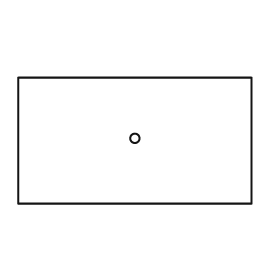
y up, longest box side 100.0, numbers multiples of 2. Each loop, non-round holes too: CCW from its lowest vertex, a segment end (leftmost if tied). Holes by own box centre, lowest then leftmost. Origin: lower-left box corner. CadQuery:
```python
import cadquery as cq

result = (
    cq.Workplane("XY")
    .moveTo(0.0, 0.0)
    .lineTo(100.0, 0.0)
    .lineTo(100.0, 54.0)
    .lineTo(0.0, 54.0)
    .close()
    .moveTo(50.0, 28.0)
    .circle(2.0)
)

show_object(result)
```